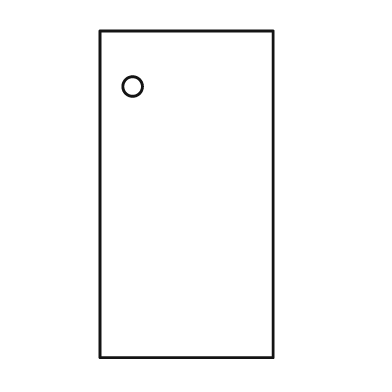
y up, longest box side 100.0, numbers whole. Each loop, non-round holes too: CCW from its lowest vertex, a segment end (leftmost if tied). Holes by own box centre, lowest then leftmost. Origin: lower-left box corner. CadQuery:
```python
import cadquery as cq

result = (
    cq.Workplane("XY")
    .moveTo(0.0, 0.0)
    .lineTo(53.0, 0.0)
    .lineTo(53.0, 100.0)
    .lineTo(0.0, 100.0)
    .close()
    .moveTo(10.0, 83.0)
    .circle(3.0)
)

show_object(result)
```